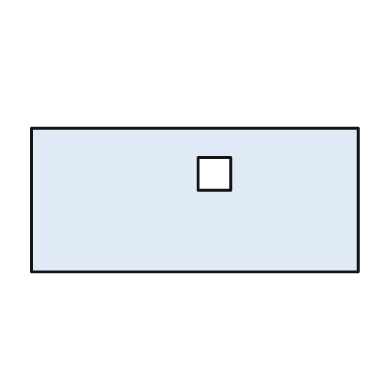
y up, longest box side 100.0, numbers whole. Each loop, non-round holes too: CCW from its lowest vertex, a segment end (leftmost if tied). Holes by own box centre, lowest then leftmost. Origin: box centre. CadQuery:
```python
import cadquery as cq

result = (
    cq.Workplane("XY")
    .moveTo(-50.0, -22.0)
    .lineTo(50.0, -22.0)
    .lineTo(50.0, 22.0)
    .lineTo(-50.0, 22.0)
    .close()
    .moveTo(1.0, 3.0)
    .lineTo(11.0, 3.0)
    .lineTo(11.0, 13.0)
    .lineTo(1.0, 13.0)
    .close()
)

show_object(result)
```